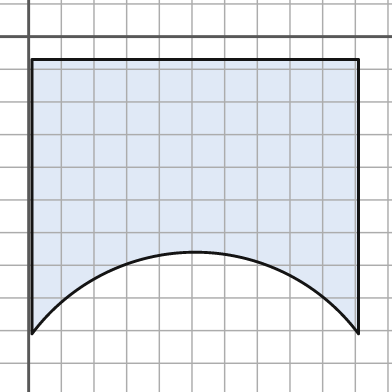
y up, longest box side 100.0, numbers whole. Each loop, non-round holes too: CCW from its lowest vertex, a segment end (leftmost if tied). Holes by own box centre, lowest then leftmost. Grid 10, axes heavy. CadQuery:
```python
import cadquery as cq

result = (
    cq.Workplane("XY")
    .moveTo(1.0, -91.0)
    .threePointArc((51.0, -66.0), (101.0, -91.0))
    .lineTo(101.0, -7.0)
    .lineTo(1.0, -7.0)
    .close()
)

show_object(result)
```